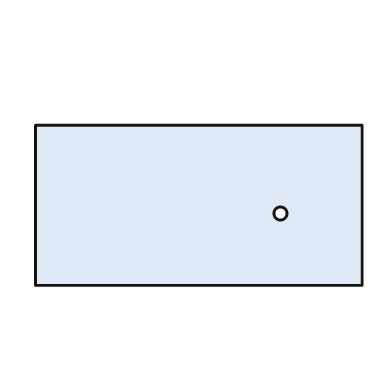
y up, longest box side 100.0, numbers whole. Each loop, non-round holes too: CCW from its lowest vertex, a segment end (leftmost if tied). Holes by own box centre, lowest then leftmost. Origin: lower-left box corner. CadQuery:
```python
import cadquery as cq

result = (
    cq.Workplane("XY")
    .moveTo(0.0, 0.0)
    .lineTo(100.0, 0.0)
    .lineTo(100.0, 49.0)
    .lineTo(0.0, 49.0)
    .close()
    .moveTo(75.0, 22.0)
    .circle(2.0)
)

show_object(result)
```